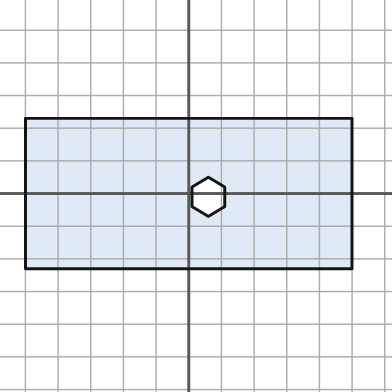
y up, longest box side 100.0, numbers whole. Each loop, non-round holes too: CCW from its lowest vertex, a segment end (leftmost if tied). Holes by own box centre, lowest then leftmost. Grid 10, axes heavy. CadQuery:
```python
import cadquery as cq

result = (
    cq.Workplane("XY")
    .moveTo(-50.0, -23.0)
    .lineTo(50.0, -23.0)
    .lineTo(50.0, 23.0)
    .lineTo(-50.0, 23.0)
    .close()
    .moveTo(6.0, -7.0)
    .lineTo(11.0, -4.0)
    .lineTo(11.0, 2.0)
    .lineTo(6.0, 5.0)
    .lineTo(1.0, 2.0)
    .lineTo(1.0, -4.0)
    .close()
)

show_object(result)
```